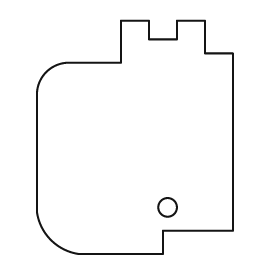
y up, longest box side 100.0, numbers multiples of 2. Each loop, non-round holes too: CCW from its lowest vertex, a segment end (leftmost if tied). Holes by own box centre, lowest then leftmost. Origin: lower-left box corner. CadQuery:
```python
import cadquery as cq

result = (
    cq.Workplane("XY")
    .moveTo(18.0, 0.0)
    .lineTo(54.0, 0.0)
    .lineTo(54.0, 10.0)
    .lineTo(84.0, 10.0)
    .lineTo(84.0, 86.0)
    .lineTo(72.0, 86.0)
    .lineTo(72.0, 100.0)
    .lineTo(60.0, 100.0)
    .lineTo(60.0, 92.0)
    .lineTo(48.0, 92.0)
    .lineTo(48.0, 100.0)
    .lineTo(36.0, 100.0)
    .lineTo(36.0, 82.0)
    .lineTo(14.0, 82.0)
    .threePointArc((4.0, 78.0), (0.0, 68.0))
    .lineTo(0.0, 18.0)
    .threePointArc((6.0, 6.0), (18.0, 0.0))
    .close()
    .moveTo(56.0, 20.0)
    .circle(4.0)
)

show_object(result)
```